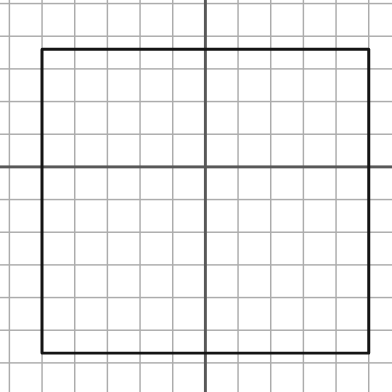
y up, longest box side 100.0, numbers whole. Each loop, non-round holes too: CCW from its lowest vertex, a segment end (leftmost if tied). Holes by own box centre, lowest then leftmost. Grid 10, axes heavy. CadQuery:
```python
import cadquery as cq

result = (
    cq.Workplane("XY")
    .moveTo(-50.0, -57.0)
    .lineTo(50.0, -57.0)
    .lineTo(50.0, 36.0)
    .lineTo(-50.0, 36.0)
    .close()
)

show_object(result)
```